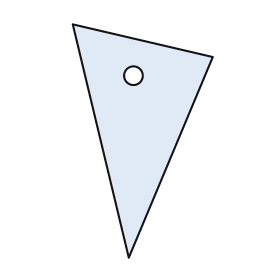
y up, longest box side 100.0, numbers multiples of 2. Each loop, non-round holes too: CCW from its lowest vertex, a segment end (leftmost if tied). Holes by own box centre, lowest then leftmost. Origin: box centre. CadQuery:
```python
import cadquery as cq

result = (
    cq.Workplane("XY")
    .moveTo(-6.0, -50.0)
    .lineTo(30.0, 36.0)
    .lineTo(-30.0, 50.0)
    .close()
    .moveTo(-4.0, 28.0)
    .circle(4.0)
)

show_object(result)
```